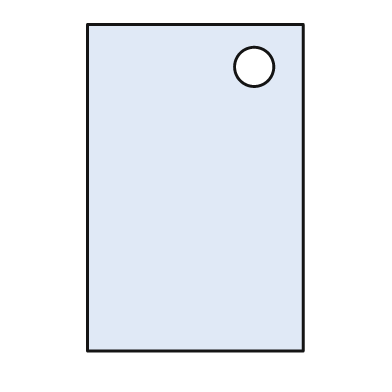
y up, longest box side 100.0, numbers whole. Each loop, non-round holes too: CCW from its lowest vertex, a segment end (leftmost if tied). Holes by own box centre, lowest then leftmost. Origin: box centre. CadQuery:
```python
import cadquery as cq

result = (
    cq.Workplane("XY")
    .moveTo(-33.0, -50.0)
    .lineTo(33.0, -50.0)
    .lineTo(33.0, 50.0)
    .lineTo(-33.0, 50.0)
    .close()
    .moveTo(18.0, 37.0)
    .circle(6.0)
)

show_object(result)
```